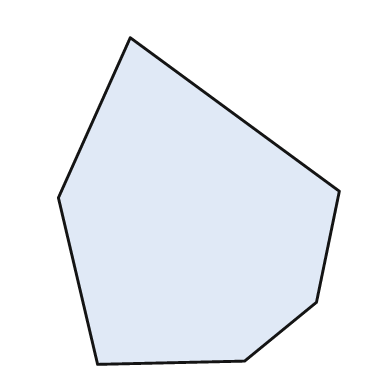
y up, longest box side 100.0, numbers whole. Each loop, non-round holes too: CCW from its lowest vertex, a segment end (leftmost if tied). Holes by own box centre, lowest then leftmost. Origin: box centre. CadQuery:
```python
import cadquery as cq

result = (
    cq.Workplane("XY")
    .moveTo(-31.0, -50.0)
    .lineTo(14.0, -49.0)
    .lineTo(36.0, -31.0)
    .lineTo(43.0, 3.0)
    .lineTo(-21.0, 50.0)
    .lineTo(-43.0, 1.0)
    .close()
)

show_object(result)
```